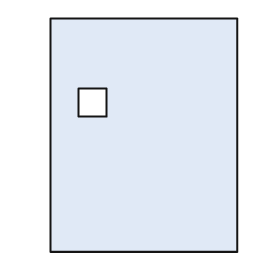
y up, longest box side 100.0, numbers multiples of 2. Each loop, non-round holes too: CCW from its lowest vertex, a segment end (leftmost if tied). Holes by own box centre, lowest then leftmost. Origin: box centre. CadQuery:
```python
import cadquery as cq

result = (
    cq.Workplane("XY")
    .moveTo(-40.0, -50.0)
    .lineTo(40.0, -50.0)
    .lineTo(40.0, 50.0)
    .lineTo(-40.0, 50.0)
    .close()
    .moveTo(-28.0, 8.0)
    .lineTo(-16.0, 8.0)
    .lineTo(-16.0, 20.0)
    .lineTo(-28.0, 20.0)
    .close()
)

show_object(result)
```